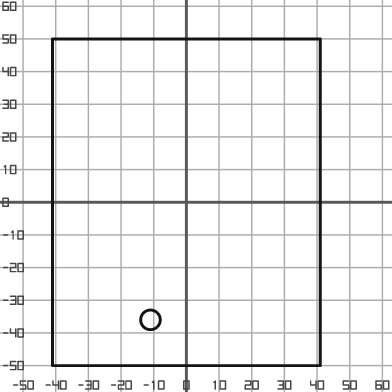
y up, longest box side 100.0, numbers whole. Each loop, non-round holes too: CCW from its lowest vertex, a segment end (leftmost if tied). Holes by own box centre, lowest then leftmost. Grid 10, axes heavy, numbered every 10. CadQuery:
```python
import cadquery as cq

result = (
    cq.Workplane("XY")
    .moveTo(-41.0, -50.0)
    .lineTo(41.0, -50.0)
    .lineTo(41.0, 50.0)
    .lineTo(-41.0, 50.0)
    .close()
    .moveTo(-11.0, -36.0)
    .circle(3.0)
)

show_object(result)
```